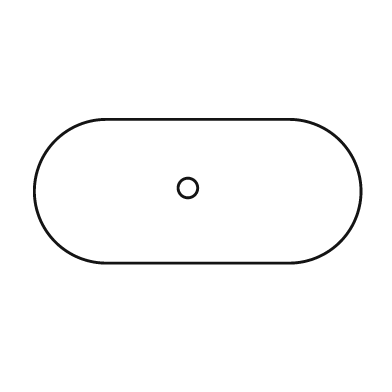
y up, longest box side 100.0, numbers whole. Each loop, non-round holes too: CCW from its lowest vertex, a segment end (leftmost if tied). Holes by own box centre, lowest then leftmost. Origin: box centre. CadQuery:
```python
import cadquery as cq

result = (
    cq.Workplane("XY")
    .moveTo(-28.0, -22.0)
    .lineTo(28.0, -22.0)
    .threePointArc((50.0, 0.0), (28.0, 22.0))
    .lineTo(-28.0, 22.0)
    .threePointArc((-50.0, 0.0), (-28.0, -22.0))
    .close()
    .moveTo(-3.0, 1.0)
    .circle(3.0)
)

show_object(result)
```